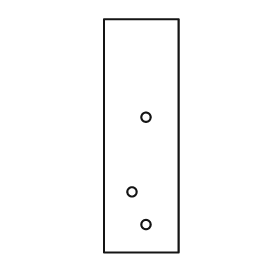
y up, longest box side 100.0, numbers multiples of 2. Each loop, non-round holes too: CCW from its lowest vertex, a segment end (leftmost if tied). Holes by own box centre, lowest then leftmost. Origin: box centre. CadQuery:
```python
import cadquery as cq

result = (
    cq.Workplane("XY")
    .moveTo(-16.0, -50.0)
    .lineTo(16.0, -50.0)
    .lineTo(16.0, 50.0)
    .lineTo(-16.0, 50.0)
    .close()
    .moveTo(2.0, -38.0)
    .circle(2.0)
    .moveTo(-4.0, -24.0)
    .circle(2.0)
    .moveTo(2.0, 8.0)
    .circle(2.0)
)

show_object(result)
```